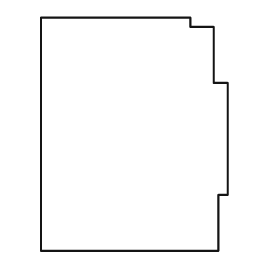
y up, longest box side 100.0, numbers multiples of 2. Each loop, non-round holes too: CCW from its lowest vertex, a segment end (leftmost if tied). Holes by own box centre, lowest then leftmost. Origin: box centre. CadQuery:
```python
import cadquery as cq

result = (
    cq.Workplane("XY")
    .moveTo(-40.0, -50.0)
    .lineTo(36.0, -50.0)
    .lineTo(36.0, -26.0)
    .lineTo(40.0, -26.0)
    .lineTo(40.0, 22.0)
    .lineTo(34.0, 22.0)
    .lineTo(34.0, 46.0)
    .lineTo(24.0, 46.0)
    .lineTo(24.0, 50.0)
    .lineTo(-40.0, 50.0)
    .close()
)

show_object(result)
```